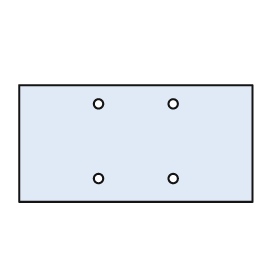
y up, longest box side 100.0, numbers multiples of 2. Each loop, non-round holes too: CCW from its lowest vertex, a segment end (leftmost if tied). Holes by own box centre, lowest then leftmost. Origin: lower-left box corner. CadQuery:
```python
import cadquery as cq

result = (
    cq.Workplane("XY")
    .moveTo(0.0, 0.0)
    .lineTo(100.0, 0.0)
    .lineTo(100.0, 50.0)
    .lineTo(0.0, 50.0)
    .close()
    .moveTo(34.0, 10.0)
    .circle(2.0)
    .moveTo(66.0, 10.0)
    .circle(2.0)
    .moveTo(34.0, 42.0)
    .circle(2.0)
    .moveTo(66.0, 42.0)
    .circle(2.0)
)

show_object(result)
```